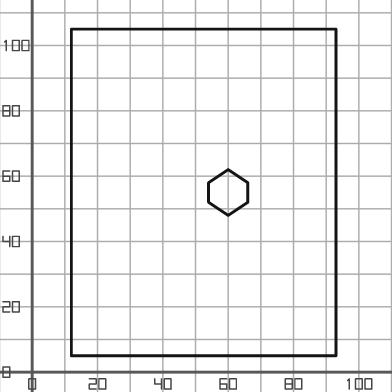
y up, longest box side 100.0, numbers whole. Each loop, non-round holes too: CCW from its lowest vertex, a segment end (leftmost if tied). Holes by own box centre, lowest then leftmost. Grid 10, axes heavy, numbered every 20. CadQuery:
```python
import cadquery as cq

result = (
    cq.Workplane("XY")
    .moveTo(12.0, 5.0)
    .lineTo(93.0, 5.0)
    .lineTo(93.0, 105.0)
    .lineTo(12.0, 105.0)
    .close()
    .moveTo(60.0, 48.0)
    .lineTo(66.0, 52.0)
    .lineTo(66.0, 58.0)
    .lineTo(60.0, 62.0)
    .lineTo(54.0, 58.0)
    .lineTo(54.0, 52.0)
    .close()
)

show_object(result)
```